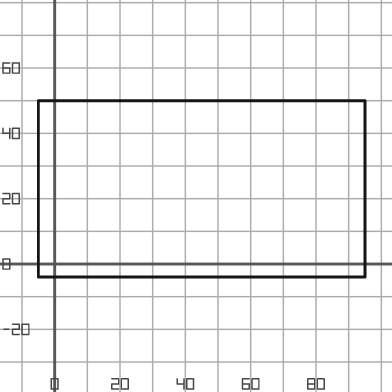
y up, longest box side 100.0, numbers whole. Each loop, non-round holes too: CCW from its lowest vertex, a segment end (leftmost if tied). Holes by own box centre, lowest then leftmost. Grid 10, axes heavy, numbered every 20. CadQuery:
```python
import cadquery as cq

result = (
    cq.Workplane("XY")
    .moveTo(-5.0, -4.0)
    .lineTo(95.0, -4.0)
    .lineTo(95.0, 50.0)
    .lineTo(-5.0, 50.0)
    .close()
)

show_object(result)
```